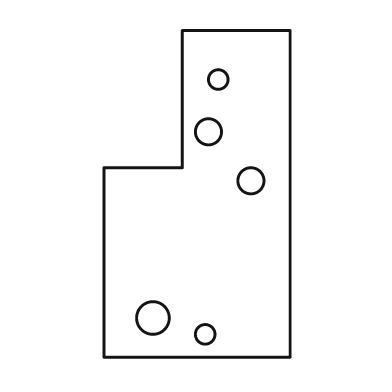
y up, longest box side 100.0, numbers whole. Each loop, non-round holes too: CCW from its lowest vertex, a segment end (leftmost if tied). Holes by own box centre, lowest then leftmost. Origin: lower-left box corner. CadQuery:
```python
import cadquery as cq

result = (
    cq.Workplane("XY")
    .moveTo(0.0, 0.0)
    .lineTo(57.0, 0.0)
    .lineTo(57.0, 100.0)
    .lineTo(24.0, 100.0)
    .lineTo(24.0, 58.0)
    .lineTo(0.0, 58.0)
    .close()
    .moveTo(31.0, 7.0)
    .circle(3.0)
    .moveTo(15.0, 12.0)
    .circle(5.0)
    .moveTo(45.0, 54.0)
    .circle(4.0)
    .moveTo(32.0, 69.0)
    .circle(4.0)
    .moveTo(35.0, 85.0)
    .circle(3.0)
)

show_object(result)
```